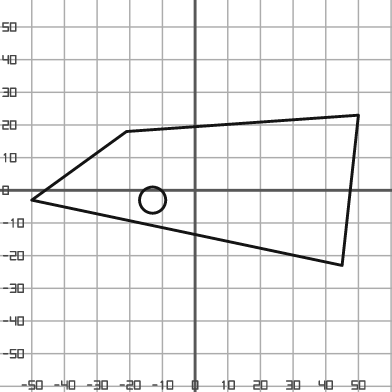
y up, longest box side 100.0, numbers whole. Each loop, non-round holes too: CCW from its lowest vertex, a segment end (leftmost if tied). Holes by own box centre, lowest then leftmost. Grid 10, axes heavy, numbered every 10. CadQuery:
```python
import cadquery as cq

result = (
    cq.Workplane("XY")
    .moveTo(45.0, -23.0)
    .lineTo(50.0, 23.0)
    .lineTo(-21.0, 18.0)
    .lineTo(-50.0, -3.0)
    .close()
    .moveTo(-13.0, -3.0)
    .circle(4.0)
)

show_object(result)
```